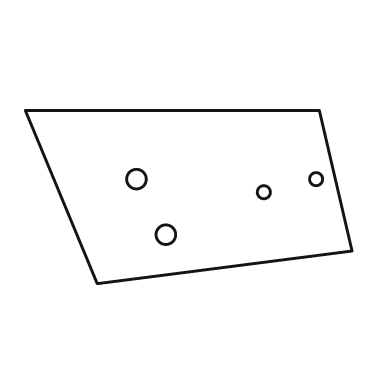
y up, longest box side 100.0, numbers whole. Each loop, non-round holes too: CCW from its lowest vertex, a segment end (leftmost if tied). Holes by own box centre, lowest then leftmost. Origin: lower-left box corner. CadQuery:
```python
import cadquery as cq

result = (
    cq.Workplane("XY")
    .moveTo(22.0, 0.0)
    .lineTo(100.0, 10.0)
    .lineTo(90.0, 53.0)
    .lineTo(0.0, 53.0)
    .close()
    .moveTo(43.0, 15.0)
    .circle(3.0)
    .moveTo(73.0, 28.0)
    .circle(2.0)
    .moveTo(34.0, 32.0)
    .circle(3.0)
    .moveTo(89.0, 32.0)
    .circle(2.0)
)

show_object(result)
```